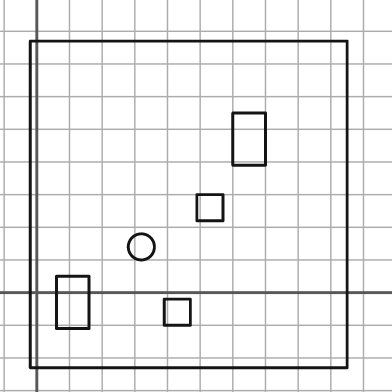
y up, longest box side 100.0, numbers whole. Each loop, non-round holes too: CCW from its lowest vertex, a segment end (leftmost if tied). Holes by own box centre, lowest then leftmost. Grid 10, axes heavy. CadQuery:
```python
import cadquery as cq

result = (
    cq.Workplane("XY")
    .moveTo(-2.0, -23.0)
    .lineTo(95.0, -23.0)
    .lineTo(95.0, 77.0)
    .lineTo(-2.0, 77.0)
    .close()
    .moveTo(39.0, -10.0)
    .lineTo(47.0, -10.0)
    .lineTo(47.0, -2.0)
    .lineTo(39.0, -2.0)
    .close()
    .moveTo(6.0, -11.0)
    .lineTo(16.0, -11.0)
    .lineTo(16.0, 5.0)
    .lineTo(6.0, 5.0)
    .close()
    .moveTo(32.0, 14.0)
    .circle(4.0)
    .moveTo(49.0, 22.0)
    .lineTo(57.0, 22.0)
    .lineTo(57.0, 30.0)
    .lineTo(49.0, 30.0)
    .close()
    .moveTo(60.0, 39.0)
    .lineTo(70.0, 39.0)
    .lineTo(70.0, 55.0)
    .lineTo(60.0, 55.0)
    .close()
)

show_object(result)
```